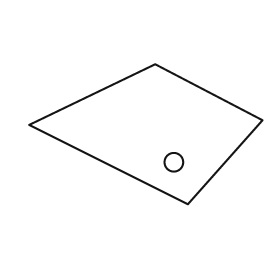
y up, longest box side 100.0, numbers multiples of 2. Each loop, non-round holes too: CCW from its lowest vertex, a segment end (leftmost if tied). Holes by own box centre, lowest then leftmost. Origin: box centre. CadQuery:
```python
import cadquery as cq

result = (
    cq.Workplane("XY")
    .moveTo(18.0, -30.0)
    .lineTo(50.0, 6.0)
    .lineTo(4.0, 30.0)
    .lineTo(-50.0, 4.0)
    .close()
    .moveTo(12.0, -12.0)
    .circle(4.0)
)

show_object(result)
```